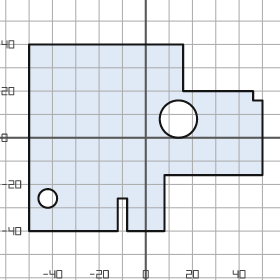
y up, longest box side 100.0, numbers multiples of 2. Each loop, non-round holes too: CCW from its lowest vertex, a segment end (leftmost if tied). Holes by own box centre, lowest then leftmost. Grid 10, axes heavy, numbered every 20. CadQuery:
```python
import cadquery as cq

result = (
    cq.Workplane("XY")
    .moveTo(-50.0, -40.0)
    .lineTo(-12.0, -40.0)
    .lineTo(-12.0, -26.0)
    .lineTo(-8.0, -26.0)
    .lineTo(-8.0, -40.0)
    .lineTo(8.0, -40.0)
    .lineTo(8.0, -16.0)
    .lineTo(50.0, -16.0)
    .lineTo(50.0, 16.0)
    .lineTo(46.0, 16.0)
    .lineTo(46.0, 20.0)
    .lineTo(16.0, 20.0)
    .lineTo(16.0, 40.0)
    .lineTo(-50.0, 40.0)
    .close()
    .moveTo(-42.0, -26.0)
    .circle(4.0)
    .moveTo(14.0, 8.0)
    .circle(8.0)
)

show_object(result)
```